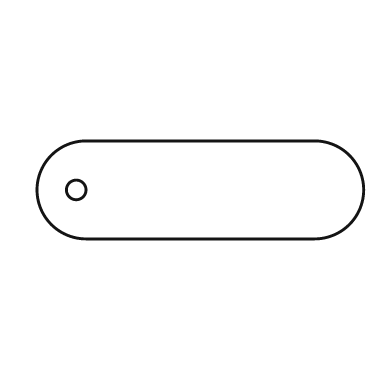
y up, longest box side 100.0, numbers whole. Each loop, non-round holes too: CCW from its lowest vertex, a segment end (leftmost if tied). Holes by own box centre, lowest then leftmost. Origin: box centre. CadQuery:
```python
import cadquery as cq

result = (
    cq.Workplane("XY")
    .moveTo(-35.0, -15.0)
    .lineTo(35.0, -15.0)
    .threePointArc((50.0, 0.0), (35.0, 15.0))
    .lineTo(-35.0, 15.0)
    .threePointArc((-50.0, 0.0), (-35.0, -15.0))
    .close()
    .moveTo(-38.0, 0.0)
    .circle(3.0)
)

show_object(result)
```